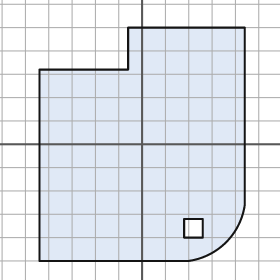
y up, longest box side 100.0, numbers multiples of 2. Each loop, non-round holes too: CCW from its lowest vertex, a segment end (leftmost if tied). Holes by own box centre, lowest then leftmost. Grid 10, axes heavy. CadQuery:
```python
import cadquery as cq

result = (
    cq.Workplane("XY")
    .moveTo(-44.0, -50.0)
    .lineTo(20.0, -50.0)
    .threePointArc((36.0, -42.0), (44.0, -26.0))
    .lineTo(44.0, 50.0)
    .lineTo(-6.0, 50.0)
    .lineTo(-6.0, 32.0)
    .lineTo(-44.0, 32.0)
    .close()
    .moveTo(18.0, -40.0)
    .lineTo(26.0, -40.0)
    .lineTo(26.0, -32.0)
    .lineTo(18.0, -32.0)
    .close()
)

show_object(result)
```